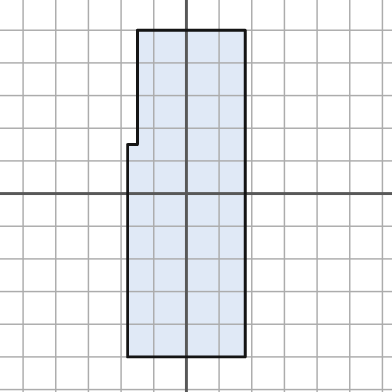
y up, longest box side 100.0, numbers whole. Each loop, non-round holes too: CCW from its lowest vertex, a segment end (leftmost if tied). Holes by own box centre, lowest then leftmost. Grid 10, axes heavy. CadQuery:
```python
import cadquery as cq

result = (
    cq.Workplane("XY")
    .moveTo(-18.0, -50.0)
    .lineTo(18.0, -50.0)
    .lineTo(18.0, 50.0)
    .lineTo(-15.0, 50.0)
    .lineTo(-15.0, 15.0)
    .lineTo(-18.0, 15.0)
    .close()
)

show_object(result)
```